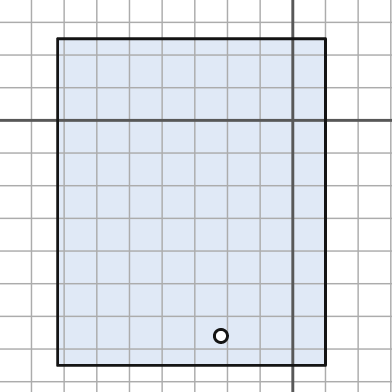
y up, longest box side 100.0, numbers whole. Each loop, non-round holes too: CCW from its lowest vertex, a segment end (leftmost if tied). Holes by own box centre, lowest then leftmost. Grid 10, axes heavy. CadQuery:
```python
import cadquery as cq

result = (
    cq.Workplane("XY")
    .moveTo(-72.0, -75.0)
    .lineTo(10.0, -75.0)
    .lineTo(10.0, 25.0)
    .lineTo(-72.0, 25.0)
    .close()
    .moveTo(-22.0, -66.0)
    .circle(2.0)
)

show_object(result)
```